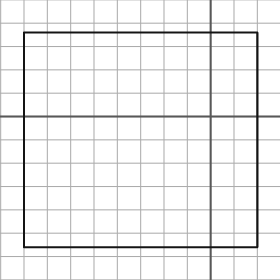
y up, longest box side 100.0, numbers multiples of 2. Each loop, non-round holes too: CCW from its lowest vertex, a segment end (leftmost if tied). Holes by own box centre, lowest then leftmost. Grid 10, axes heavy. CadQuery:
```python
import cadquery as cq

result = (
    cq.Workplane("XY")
    .moveTo(-80.0, -56.0)
    .lineTo(20.0, -56.0)
    .lineTo(20.0, 36.0)
    .lineTo(-80.0, 36.0)
    .close()
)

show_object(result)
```